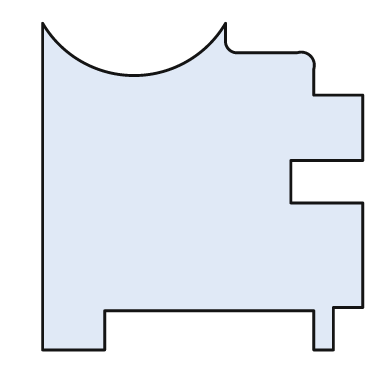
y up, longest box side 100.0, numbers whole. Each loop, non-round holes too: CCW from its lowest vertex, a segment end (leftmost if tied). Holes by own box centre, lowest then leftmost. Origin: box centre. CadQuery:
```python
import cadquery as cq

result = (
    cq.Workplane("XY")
    .moveTo(-49.0, -50.0)
    .lineTo(-30.0, -50.0)
    .lineTo(-30.0, -38.0)
    .lineTo(34.0, -38.0)
    .lineTo(34.0, -50.0)
    .lineTo(40.0, -50.0)
    .lineTo(40.0, -37.0)
    .lineTo(49.0, -37.0)
    .lineTo(49.0, -5.0)
    .lineTo(27.0, -5.0)
    .lineTo(27.0, 8.0)
    .lineTo(49.0, 8.0)
    .lineTo(49.0, 28.0)
    .lineTo(34.0, 28.0)
    .lineTo(34.0, 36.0)
    .threePointArc((33.0, 40.0), (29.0, 41.0))
    .lineTo(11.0, 41.0)
    .threePointArc((8.0, 42.0), (7.0, 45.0))
    .lineTo(7.0, 50.0)
    .threePointArc((-21.0, 34.0), (-49.0, 50.0))
    .close()
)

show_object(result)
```